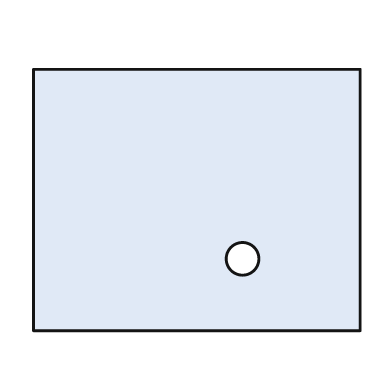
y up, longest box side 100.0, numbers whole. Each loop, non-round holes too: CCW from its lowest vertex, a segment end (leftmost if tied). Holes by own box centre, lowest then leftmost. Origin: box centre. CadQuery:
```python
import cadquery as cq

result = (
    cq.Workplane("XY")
    .moveTo(-50.0, -40.0)
    .lineTo(50.0, -40.0)
    .lineTo(50.0, 40.0)
    .lineTo(-50.0, 40.0)
    .close()
    .moveTo(14.0, -18.0)
    .circle(5.0)
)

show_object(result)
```